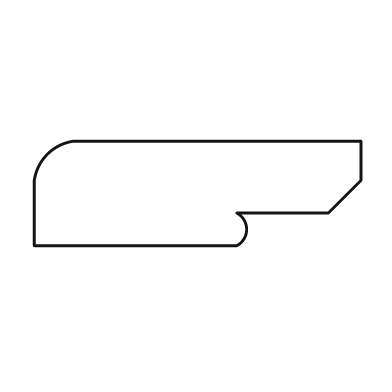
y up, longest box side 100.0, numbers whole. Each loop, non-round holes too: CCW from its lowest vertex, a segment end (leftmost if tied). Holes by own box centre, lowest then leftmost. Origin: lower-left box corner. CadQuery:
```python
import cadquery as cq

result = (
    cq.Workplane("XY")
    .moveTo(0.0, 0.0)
    .lineTo(62.0, 0.0)
    .threePointArc((65.0, 5.0), (62.0, 10.0))
    .lineTo(90.0, 10.0)
    .lineTo(100.0, 20.0)
    .lineTo(100.0, 32.0)
    .lineTo(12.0, 32.0)
    .threePointArc((4.0, 28.0), (0.0, 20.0))
    .close()
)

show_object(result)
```